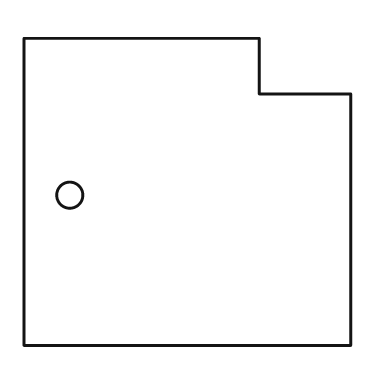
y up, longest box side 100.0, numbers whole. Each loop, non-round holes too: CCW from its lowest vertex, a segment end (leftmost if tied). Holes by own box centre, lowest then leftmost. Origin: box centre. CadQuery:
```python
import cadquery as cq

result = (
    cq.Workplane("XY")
    .moveTo(-50.0, -47.0)
    .lineTo(50.0, -47.0)
    .lineTo(50.0, 30.0)
    .lineTo(22.0, 30.0)
    .lineTo(22.0, 47.0)
    .lineTo(-50.0, 47.0)
    .close()
    .moveTo(-36.0, -1.0)
    .circle(4.0)
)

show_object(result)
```